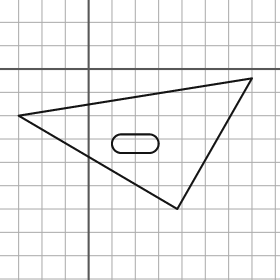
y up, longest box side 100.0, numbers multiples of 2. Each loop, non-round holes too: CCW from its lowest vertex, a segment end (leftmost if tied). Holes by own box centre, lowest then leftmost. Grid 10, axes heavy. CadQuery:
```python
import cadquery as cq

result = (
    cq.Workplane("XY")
    .moveTo(38.0, -60.0)
    .lineTo(70.0, -4.0)
    .lineTo(-30.0, -20.0)
    .close()
    .moveTo(14.0, -36.0)
    .lineTo(26.0, -36.0)
    .threePointArc((30.0, -32.0), (26.0, -28.0))
    .lineTo(14.0, -28.0)
    .threePointArc((10.0, -32.0), (14.0, -36.0))
    .close()
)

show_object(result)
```